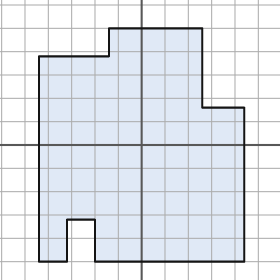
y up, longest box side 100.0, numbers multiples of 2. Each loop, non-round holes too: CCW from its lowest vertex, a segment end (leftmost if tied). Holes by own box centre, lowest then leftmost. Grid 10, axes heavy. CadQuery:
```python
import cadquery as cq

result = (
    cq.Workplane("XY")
    .moveTo(-44.0, -50.0)
    .lineTo(-32.0, -50.0)
    .lineTo(-32.0, -32.0)
    .lineTo(-20.0, -32.0)
    .lineTo(-20.0, -50.0)
    .lineTo(44.0, -50.0)
    .lineTo(44.0, 16.0)
    .lineTo(26.0, 16.0)
    .lineTo(26.0, 50.0)
    .lineTo(-14.0, 50.0)
    .lineTo(-14.0, 38.0)
    .lineTo(-44.0, 38.0)
    .close()
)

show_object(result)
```